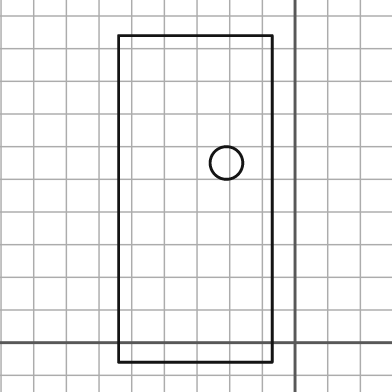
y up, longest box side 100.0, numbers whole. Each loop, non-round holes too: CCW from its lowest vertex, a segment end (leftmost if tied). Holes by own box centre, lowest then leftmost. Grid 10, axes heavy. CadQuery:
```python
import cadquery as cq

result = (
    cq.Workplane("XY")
    .moveTo(-54.0, -6.0)
    .lineTo(-7.0, -6.0)
    .lineTo(-7.0, 94.0)
    .lineTo(-54.0, 94.0)
    .close()
    .moveTo(-21.0, 55.0)
    .circle(5.0)
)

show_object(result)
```